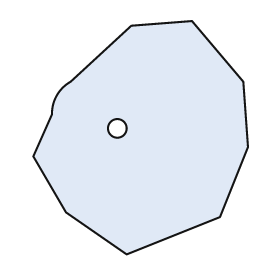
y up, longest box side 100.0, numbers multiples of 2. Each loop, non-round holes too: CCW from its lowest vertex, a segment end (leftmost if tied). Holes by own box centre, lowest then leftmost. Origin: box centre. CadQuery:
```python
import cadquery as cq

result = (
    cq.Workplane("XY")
    .moveTo(-6.0, -50.0)
    .lineTo(34.0, -34.0)
    .lineTo(46.0, -4.0)
    .lineTo(44.0, 24.0)
    .lineTo(22.0, 50.0)
    .lineTo(-4.0, 48.0)
    .lineTo(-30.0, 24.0)
    .threePointArc((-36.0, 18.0), (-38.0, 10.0))
    .lineTo(-46.0, -8.0)
    .lineTo(-32.0, -32.0)
    .close()
    .moveTo(-10.0, 4.0)
    .circle(4.0)
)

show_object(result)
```